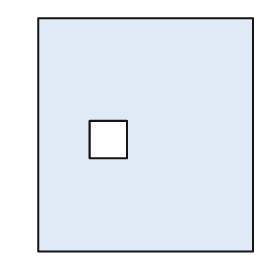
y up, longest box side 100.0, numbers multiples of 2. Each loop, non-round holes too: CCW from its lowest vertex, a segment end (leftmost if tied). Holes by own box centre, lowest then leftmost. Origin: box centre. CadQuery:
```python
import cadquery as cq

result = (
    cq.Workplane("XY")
    .moveTo(-46.0, -50.0)
    .lineTo(46.0, -50.0)
    .lineTo(46.0, 50.0)
    .lineTo(-46.0, 50.0)
    .close()
    .moveTo(-24.0, -10.0)
    .lineTo(-8.0, -10.0)
    .lineTo(-8.0, 6.0)
    .lineTo(-24.0, 6.0)
    .close()
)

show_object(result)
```